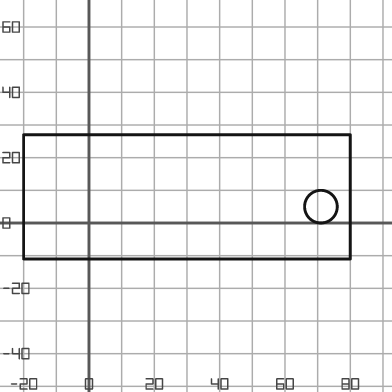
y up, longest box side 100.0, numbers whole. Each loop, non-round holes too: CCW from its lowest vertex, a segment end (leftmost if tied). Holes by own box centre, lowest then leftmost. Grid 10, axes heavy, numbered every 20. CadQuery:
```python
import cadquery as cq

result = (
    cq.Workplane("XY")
    .moveTo(-20.0, -11.0)
    .lineTo(80.0, -11.0)
    .lineTo(80.0, 27.0)
    .lineTo(-20.0, 27.0)
    .close()
    .moveTo(71.0, 5.0)
    .circle(5.0)
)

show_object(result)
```